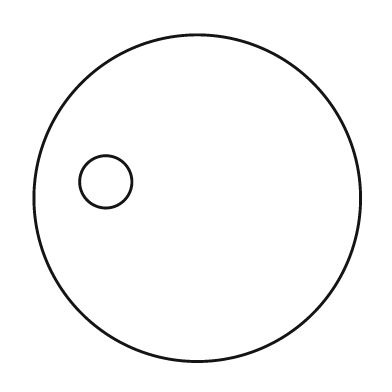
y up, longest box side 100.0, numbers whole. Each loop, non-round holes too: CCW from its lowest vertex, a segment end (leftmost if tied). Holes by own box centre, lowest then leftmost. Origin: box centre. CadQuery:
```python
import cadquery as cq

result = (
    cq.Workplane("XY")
    .moveTo(0.0, 0.0)
    .circle(50.0)
    .moveTo(-28.0, 5.0)
    .circle(8.0)
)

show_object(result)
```